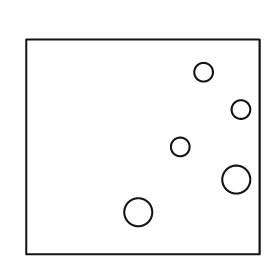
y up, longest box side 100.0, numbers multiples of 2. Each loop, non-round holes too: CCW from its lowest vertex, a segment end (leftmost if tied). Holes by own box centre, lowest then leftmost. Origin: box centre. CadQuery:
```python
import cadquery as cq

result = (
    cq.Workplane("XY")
    .moveTo(-50.0, -46.0)
    .lineTo(50.0, -46.0)
    .lineTo(50.0, 46.0)
    .lineTo(-50.0, 46.0)
    .close()
    .moveTo(-2.0, -28.0)
    .circle(6.0)
    .moveTo(40.0, -14.0)
    .circle(6.0)
    .moveTo(16.0, 0.0)
    .circle(4.0)
    .moveTo(42.0, 16.0)
    .circle(4.0)
    .moveTo(26.0, 32.0)
    .circle(4.0)
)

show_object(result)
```